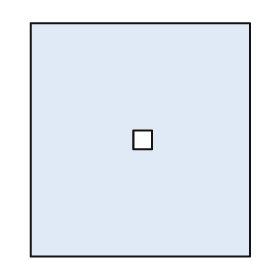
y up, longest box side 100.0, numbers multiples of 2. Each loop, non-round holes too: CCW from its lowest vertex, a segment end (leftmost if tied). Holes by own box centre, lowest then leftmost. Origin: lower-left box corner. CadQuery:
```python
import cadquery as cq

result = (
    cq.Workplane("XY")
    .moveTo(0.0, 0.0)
    .lineTo(94.0, 0.0)
    .lineTo(94.0, 100.0)
    .lineTo(0.0, 100.0)
    .close()
    .moveTo(44.0, 46.0)
    .lineTo(52.0, 46.0)
    .lineTo(52.0, 54.0)
    .lineTo(44.0, 54.0)
    .close()
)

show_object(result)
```